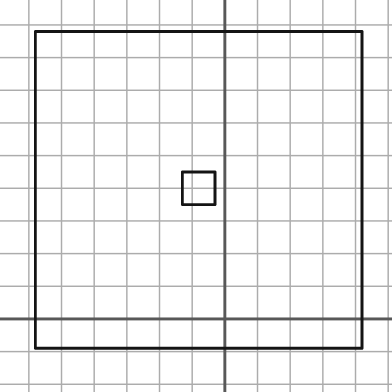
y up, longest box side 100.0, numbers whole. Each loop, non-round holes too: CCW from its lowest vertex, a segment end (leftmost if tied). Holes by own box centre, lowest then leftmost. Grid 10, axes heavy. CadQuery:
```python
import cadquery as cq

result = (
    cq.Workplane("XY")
    .moveTo(-58.0, -9.0)
    .lineTo(42.0, -9.0)
    .lineTo(42.0, 88.0)
    .lineTo(-58.0, 88.0)
    .close()
    .moveTo(-13.0, 35.0)
    .lineTo(-3.0, 35.0)
    .lineTo(-3.0, 45.0)
    .lineTo(-13.0, 45.0)
    .close()
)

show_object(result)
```